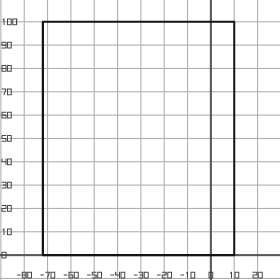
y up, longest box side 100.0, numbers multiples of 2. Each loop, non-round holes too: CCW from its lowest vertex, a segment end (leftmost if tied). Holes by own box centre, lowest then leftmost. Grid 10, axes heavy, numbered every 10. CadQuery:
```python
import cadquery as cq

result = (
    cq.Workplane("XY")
    .moveTo(-72.0, 0.0)
    .lineTo(10.0, 0.0)
    .lineTo(10.0, 100.0)
    .lineTo(-72.0, 100.0)
    .close()
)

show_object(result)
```